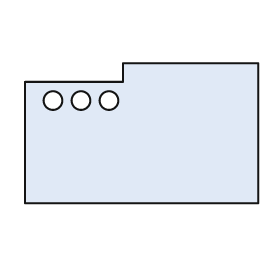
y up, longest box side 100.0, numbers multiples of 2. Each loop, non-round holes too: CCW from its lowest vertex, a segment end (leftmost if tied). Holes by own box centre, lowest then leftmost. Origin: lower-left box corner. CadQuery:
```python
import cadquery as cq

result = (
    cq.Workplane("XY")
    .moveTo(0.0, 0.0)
    .lineTo(100.0, 0.0)
    .lineTo(100.0, 60.0)
    .lineTo(42.0, 60.0)
    .lineTo(42.0, 52.0)
    .lineTo(0.0, 52.0)
    .close()
    .moveTo(12.0, 44.0)
    .circle(4.0)
    .moveTo(24.0, 44.0)
    .circle(4.0)
    .moveTo(36.0, 44.0)
    .circle(4.0)
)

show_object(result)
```